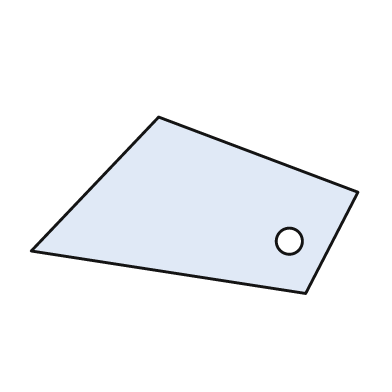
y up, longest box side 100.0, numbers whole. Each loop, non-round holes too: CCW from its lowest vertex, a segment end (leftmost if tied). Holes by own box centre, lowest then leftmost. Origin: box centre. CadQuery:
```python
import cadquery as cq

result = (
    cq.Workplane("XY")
    .moveTo(34.0, -27.0)
    .lineTo(50.0, 4.0)
    .lineTo(-11.0, 27.0)
    .lineTo(-50.0, -14.0)
    .close()
    .moveTo(29.0, -11.0)
    .circle(4.0)
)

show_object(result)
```